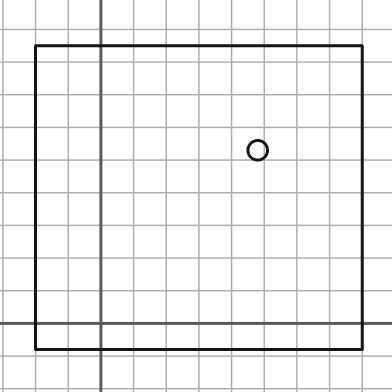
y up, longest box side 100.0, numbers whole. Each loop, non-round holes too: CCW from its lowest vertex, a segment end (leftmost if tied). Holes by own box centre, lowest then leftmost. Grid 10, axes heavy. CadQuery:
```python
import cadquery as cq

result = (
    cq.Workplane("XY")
    .moveTo(-20.0, -8.0)
    .lineTo(80.0, -8.0)
    .lineTo(80.0, 85.0)
    .lineTo(-20.0, 85.0)
    .close()
    .moveTo(48.0, 53.0)
    .circle(3.0)
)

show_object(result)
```